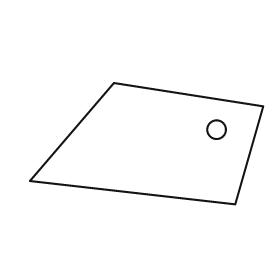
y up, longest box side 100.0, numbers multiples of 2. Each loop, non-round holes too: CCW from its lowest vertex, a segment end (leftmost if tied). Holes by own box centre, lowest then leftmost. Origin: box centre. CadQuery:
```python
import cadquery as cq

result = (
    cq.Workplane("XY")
    .moveTo(38.0, -26.0)
    .lineTo(50.0, 16.0)
    .lineTo(-14.0, 26.0)
    .lineTo(-50.0, -16.0)
    .close()
    .moveTo(30.0, 6.0)
    .circle(4.0)
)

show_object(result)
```